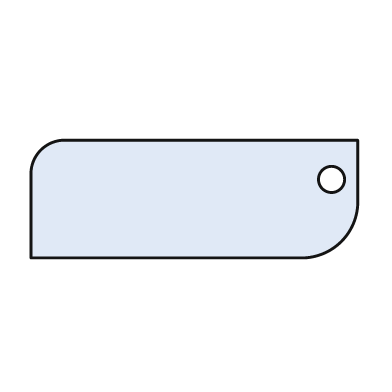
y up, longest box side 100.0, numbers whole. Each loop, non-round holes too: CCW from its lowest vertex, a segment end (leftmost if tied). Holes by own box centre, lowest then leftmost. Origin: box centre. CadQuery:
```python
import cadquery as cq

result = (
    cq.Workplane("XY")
    .moveTo(-50.0, -18.0)
    .lineTo(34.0, -18.0)
    .threePointArc((45.0, -13.0), (50.0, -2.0))
    .lineTo(50.0, 18.0)
    .lineTo(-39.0, 18.0)
    .threePointArc((-47.0, 15.0), (-50.0, 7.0))
    .close()
    .moveTo(42.0, 6.0)
    .circle(4.0)
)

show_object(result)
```